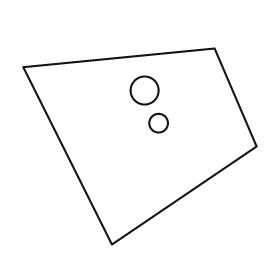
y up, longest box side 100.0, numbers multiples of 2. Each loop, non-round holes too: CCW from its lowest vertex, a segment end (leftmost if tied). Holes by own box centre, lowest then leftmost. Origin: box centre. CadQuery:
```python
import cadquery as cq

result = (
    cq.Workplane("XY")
    .moveTo(-12.0, -42.0)
    .lineTo(50.0, 0.0)
    .lineTo(32.0, 42.0)
    .lineTo(-50.0, 34.0)
    .close()
    .moveTo(8.0, 10.0)
    .circle(4.0)
    .moveTo(2.0, 24.0)
    .circle(6.0)
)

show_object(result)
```